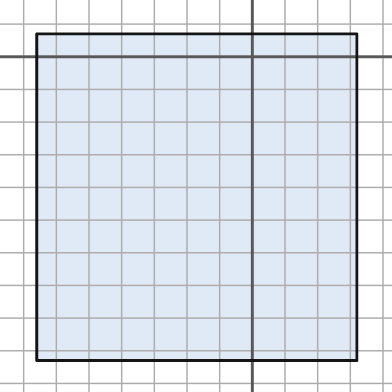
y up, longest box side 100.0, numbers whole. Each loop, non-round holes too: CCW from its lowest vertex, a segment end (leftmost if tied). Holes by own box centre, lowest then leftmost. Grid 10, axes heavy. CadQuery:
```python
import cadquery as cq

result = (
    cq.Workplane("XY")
    .moveTo(-66.0, -93.0)
    .lineTo(32.0, -93.0)
    .lineTo(32.0, 7.0)
    .lineTo(-66.0, 7.0)
    .close()
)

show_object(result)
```